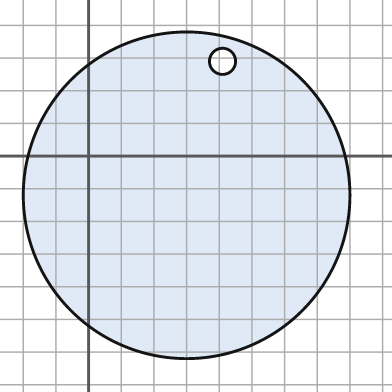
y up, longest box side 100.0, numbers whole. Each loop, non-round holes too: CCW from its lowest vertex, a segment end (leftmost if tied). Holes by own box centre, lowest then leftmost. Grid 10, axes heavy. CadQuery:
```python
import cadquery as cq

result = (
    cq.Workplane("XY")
    .moveTo(30.0, -12.0)
    .circle(50.0)
    .moveTo(41.0, 29.0)
    .circle(4.0)
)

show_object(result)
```